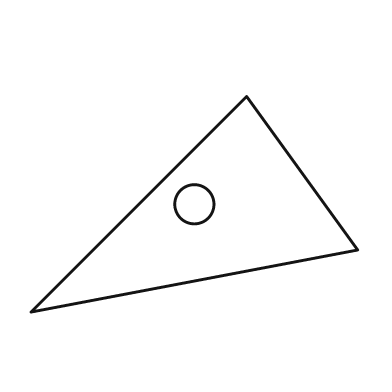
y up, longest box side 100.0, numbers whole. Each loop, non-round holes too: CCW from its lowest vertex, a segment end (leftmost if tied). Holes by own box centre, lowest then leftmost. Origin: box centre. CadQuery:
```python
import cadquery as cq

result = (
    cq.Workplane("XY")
    .moveTo(-50.0, -33.0)
    .lineTo(50.0, -14.0)
    .lineTo(16.0, 33.0)
    .close()
    .moveTo(0.0, 0.0)
    .circle(6.0)
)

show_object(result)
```